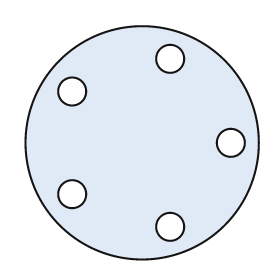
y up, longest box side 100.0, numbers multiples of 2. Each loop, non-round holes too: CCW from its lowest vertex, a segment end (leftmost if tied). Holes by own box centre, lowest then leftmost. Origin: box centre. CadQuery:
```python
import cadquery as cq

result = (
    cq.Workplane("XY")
    .moveTo(0.0, 0.0)
    .circle(50.0)
    .moveTo(12.0, -36.0)
    .circle(6.0)
    .moveTo(-30.0, -22.0)
    .circle(6.0)
    .moveTo(38.0, 0.0)
    .circle(6.0)
    .moveTo(-30.0, 22.0)
    .circle(6.0)
    .moveTo(12.0, 36.0)
    .circle(6.0)
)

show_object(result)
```